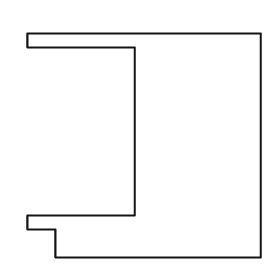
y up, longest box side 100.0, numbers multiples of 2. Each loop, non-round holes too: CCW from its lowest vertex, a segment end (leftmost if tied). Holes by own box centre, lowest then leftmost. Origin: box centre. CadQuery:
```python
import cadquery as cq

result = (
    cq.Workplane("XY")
    .moveTo(-38.0, -48.0)
    .lineTo(50.0, -48.0)
    .lineTo(50.0, 48.0)
    .lineTo(-50.0, 48.0)
    .lineTo(-50.0, 42.0)
    .lineTo(-4.0, 42.0)
    .lineTo(-4.0, -30.0)
    .lineTo(-50.0, -30.0)
    .lineTo(-50.0, -36.0)
    .lineTo(-38.0, -36.0)
    .close()
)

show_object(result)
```